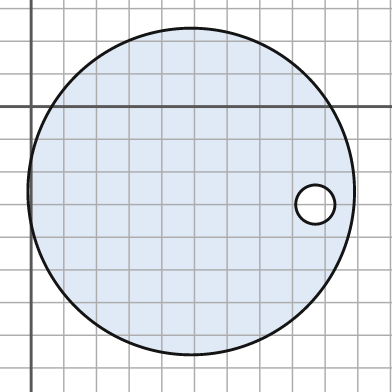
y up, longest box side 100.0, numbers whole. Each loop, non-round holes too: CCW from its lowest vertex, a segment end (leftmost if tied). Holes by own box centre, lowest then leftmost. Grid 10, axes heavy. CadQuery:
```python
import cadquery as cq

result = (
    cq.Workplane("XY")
    .moveTo(49.0, -26.0)
    .circle(50.0)
    .moveTo(87.0, -30.0)
    .circle(6.0)
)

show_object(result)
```